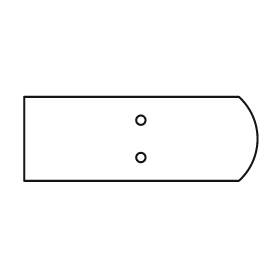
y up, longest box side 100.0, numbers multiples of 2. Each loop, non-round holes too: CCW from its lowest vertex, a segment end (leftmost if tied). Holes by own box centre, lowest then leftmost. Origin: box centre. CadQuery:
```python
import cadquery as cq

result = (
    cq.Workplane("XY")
    .moveTo(-50.0, -18.0)
    .lineTo(42.0, -18.0)
    .threePointArc((50.0, 0.0), (42.0, 18.0))
    .lineTo(-50.0, 18.0)
    .close()
    .moveTo(0.0, -8.0)
    .circle(2.0)
    .moveTo(0.0, 8.0)
    .circle(2.0)
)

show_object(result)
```